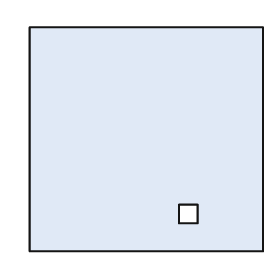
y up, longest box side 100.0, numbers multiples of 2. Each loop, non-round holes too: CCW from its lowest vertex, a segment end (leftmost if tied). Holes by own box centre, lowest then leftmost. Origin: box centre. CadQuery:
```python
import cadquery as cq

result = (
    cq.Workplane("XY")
    .moveTo(-50.0, -48.0)
    .lineTo(50.0, -48.0)
    .lineTo(50.0, 48.0)
    .lineTo(-50.0, 48.0)
    .close()
    .moveTo(14.0, -36.0)
    .lineTo(22.0, -36.0)
    .lineTo(22.0, -28.0)
    .lineTo(14.0, -28.0)
    .close()
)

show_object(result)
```